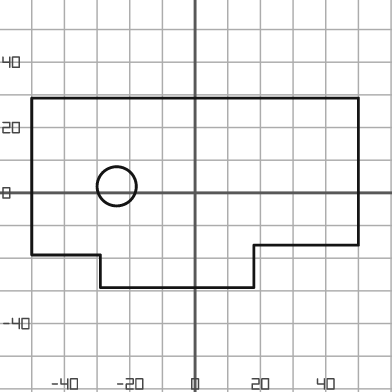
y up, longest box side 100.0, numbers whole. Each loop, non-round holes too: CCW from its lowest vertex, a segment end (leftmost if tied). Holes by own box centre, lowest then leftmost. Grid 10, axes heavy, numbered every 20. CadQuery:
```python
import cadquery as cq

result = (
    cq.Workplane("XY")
    .moveTo(-29.0, -29.0)
    .lineTo(18.0, -29.0)
    .lineTo(18.0, -16.0)
    .lineTo(50.0, -16.0)
    .lineTo(50.0, 29.0)
    .lineTo(-50.0, 29.0)
    .lineTo(-50.0, -19.0)
    .lineTo(-29.0, -19.0)
    .close()
    .moveTo(-24.0, 2.0)
    .circle(6.0)
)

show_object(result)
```